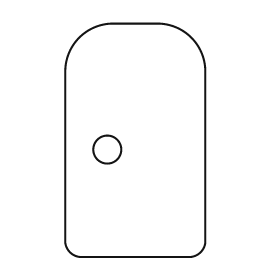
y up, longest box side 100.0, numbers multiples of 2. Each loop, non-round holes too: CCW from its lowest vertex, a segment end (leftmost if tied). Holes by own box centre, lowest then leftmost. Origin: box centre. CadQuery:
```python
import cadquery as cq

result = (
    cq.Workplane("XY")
    .moveTo(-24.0, -50.0)
    .lineTo(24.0, -50.0)
    .threePointArc((28.0, -48.0), (30.0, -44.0))
    .lineTo(30.0, 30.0)
    .threePointArc((24.0, 44.0), (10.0, 50.0))
    .lineTo(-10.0, 50.0)
    .threePointArc((-24.0, 44.0), (-30.0, 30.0))
    .lineTo(-30.0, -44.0)
    .threePointArc((-28.0, -48.0), (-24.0, -50.0))
    .close()
    .moveTo(-12.0, -4.0)
    .circle(6.0)
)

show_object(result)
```